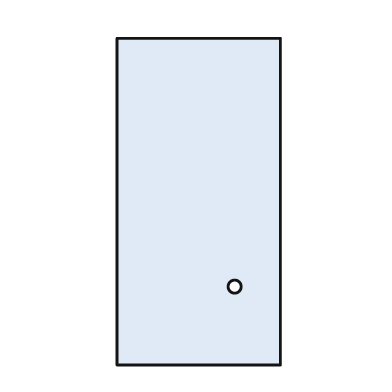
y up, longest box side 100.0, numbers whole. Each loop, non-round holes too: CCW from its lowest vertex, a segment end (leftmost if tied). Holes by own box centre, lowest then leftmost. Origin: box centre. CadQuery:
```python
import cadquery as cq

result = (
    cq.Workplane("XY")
    .moveTo(-25.0, -50.0)
    .lineTo(25.0, -50.0)
    .lineTo(25.0, 50.0)
    .lineTo(-25.0, 50.0)
    .close()
    .moveTo(11.0, -26.0)
    .circle(2.0)
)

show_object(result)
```